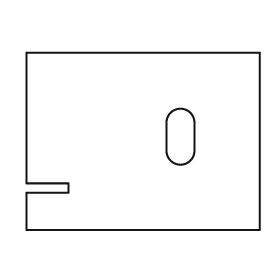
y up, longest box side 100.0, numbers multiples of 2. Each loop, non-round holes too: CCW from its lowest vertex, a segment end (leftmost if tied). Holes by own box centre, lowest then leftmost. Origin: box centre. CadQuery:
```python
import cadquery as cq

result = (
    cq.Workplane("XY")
    .moveTo(-50.0, -38.0)
    .lineTo(50.0, -38.0)
    .lineTo(50.0, 38.0)
    .lineTo(-50.0, 38.0)
    .lineTo(-50.0, -18.0)
    .lineTo(-32.0, -18.0)
    .lineTo(-32.0, -22.0)
    .lineTo(-50.0, -22.0)
    .close()
    .moveTo(10.0, -4.0)
    .threePointArc((16.0, -10.0), (22.0, -4.0))
    .lineTo(22.0, 8.0)
    .threePointArc((16.0, 14.0), (10.0, 8.0))
    .close()
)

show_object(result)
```